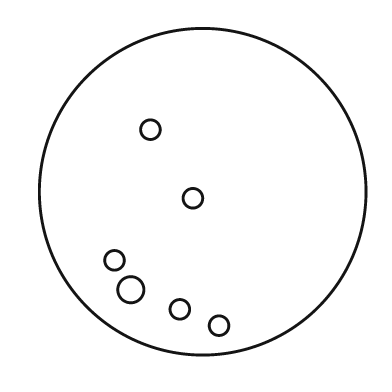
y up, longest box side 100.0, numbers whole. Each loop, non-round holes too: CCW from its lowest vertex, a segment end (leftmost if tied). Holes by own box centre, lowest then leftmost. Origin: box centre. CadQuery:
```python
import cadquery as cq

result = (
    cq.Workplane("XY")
    .moveTo(0.0, 0.0)
    .circle(50.0)
    .moveTo(5.0, -41.0)
    .circle(3.0)
    .moveTo(-7.0, -36.0)
    .circle(3.0)
    .moveTo(-22.0, -30.0)
    .circle(4.0)
    .moveTo(-27.0, -21.0)
    .circle(3.0)
    .moveTo(-3.0, -2.0)
    .circle(3.0)
    .moveTo(-16.0, 19.0)
    .circle(3.0)
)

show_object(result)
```